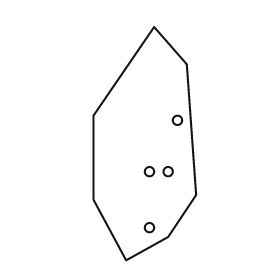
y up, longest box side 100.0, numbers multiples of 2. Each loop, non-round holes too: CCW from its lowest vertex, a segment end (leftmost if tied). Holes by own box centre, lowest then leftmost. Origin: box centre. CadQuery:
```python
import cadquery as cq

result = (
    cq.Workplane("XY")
    .moveTo(-8.0, -50.0)
    .lineTo(10.0, -40.0)
    .lineTo(22.0, -22.0)
    .lineTo(18.0, 34.0)
    .lineTo(4.0, 50.0)
    .lineTo(-22.0, 12.0)
    .lineTo(-22.0, -24.0)
    .close()
    .moveTo(2.0, -36.0)
    .circle(2.0)
    .moveTo(2.0, -12.0)
    .circle(2.0)
    .moveTo(10.0, -12.0)
    .circle(2.0)
    .moveTo(14.0, 10.0)
    .circle(2.0)
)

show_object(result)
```